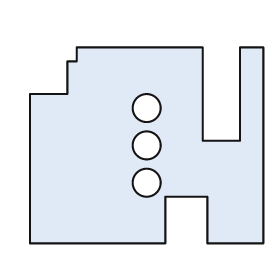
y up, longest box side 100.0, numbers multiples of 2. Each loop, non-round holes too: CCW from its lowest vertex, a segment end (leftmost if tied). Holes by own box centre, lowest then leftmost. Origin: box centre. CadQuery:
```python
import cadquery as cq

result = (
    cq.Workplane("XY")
    .moveTo(-50.0, -42.0)
    .lineTo(8.0, -42.0)
    .lineTo(8.0, -22.0)
    .lineTo(26.0, -22.0)
    .lineTo(26.0, -42.0)
    .lineTo(50.0, -42.0)
    .lineTo(50.0, 42.0)
    .lineTo(40.0, 42.0)
    .lineTo(40.0, 2.0)
    .lineTo(24.0, 2.0)
    .lineTo(24.0, 42.0)
    .lineTo(-30.0, 42.0)
    .lineTo(-30.0, 36.0)
    .lineTo(-34.0, 36.0)
    .lineTo(-34.0, 22.0)
    .lineTo(-50.0, 22.0)
    .close()
    .moveTo(0.0, -16.0)
    .circle(6.0)
    .moveTo(0.0, 0.0)
    .circle(6.0)
    .moveTo(0.0, 16.0)
    .circle(6.0)
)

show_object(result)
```